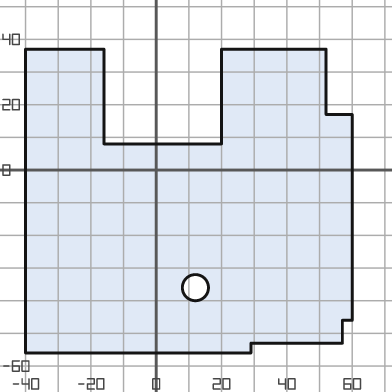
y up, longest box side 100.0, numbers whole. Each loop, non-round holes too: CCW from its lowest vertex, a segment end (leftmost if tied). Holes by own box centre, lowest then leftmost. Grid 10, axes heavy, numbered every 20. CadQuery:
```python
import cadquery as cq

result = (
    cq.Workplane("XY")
    .moveTo(-40.0, -56.0)
    .lineTo(29.0, -56.0)
    .lineTo(29.0, -53.0)
    .lineTo(57.0, -53.0)
    .lineTo(57.0, -46.0)
    .lineTo(60.0, -46.0)
    .lineTo(60.0, 17.0)
    .lineTo(52.0, 17.0)
    .lineTo(52.0, 37.0)
    .lineTo(20.0, 37.0)
    .lineTo(20.0, 8.0)
    .lineTo(-16.0, 8.0)
    .lineTo(-16.0, 37.0)
    .lineTo(-40.0, 37.0)
    .close()
    .moveTo(12.0, -36.0)
    .circle(4.0)
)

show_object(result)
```